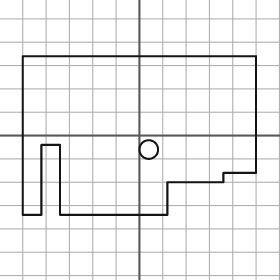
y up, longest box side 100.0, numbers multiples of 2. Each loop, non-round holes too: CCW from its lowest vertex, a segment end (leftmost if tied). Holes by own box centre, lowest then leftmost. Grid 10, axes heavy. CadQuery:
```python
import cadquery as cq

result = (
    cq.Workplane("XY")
    .moveTo(-50.0, -34.0)
    .lineTo(-42.0, -34.0)
    .lineTo(-42.0, -4.0)
    .lineTo(-34.0, -4.0)
    .lineTo(-34.0, -34.0)
    .lineTo(12.0, -34.0)
    .lineTo(12.0, -20.0)
    .lineTo(36.0, -20.0)
    .lineTo(36.0, -16.0)
    .lineTo(50.0, -16.0)
    .lineTo(50.0, 34.0)
    .lineTo(-50.0, 34.0)
    .close()
    .moveTo(4.0, -6.0)
    .circle(4.0)
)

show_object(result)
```